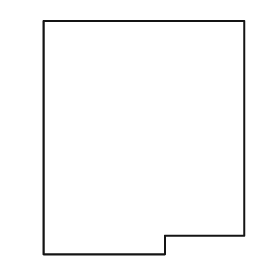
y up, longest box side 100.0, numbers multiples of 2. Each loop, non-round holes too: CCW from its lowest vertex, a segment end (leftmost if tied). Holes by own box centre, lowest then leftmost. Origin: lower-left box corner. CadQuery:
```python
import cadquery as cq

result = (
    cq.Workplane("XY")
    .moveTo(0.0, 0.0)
    .lineTo(52.0, 0.0)
    .lineTo(52.0, 8.0)
    .lineTo(86.0, 8.0)
    .lineTo(86.0, 100.0)
    .lineTo(0.0, 100.0)
    .close()
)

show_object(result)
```